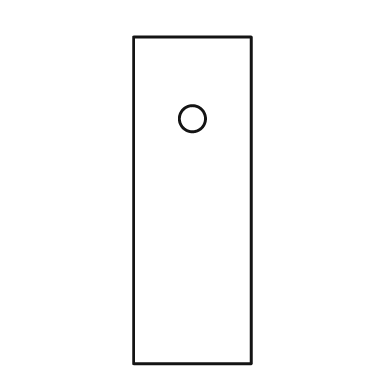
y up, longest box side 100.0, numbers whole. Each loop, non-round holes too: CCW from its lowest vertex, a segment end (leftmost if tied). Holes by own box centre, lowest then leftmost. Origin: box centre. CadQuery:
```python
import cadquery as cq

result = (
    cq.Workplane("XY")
    .moveTo(-18.0, -50.0)
    .lineTo(18.0, -50.0)
    .lineTo(18.0, 50.0)
    .lineTo(-18.0, 50.0)
    .close()
    .moveTo(0.0, 25.0)
    .circle(4.0)
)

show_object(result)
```